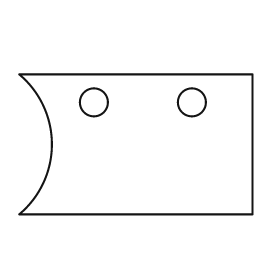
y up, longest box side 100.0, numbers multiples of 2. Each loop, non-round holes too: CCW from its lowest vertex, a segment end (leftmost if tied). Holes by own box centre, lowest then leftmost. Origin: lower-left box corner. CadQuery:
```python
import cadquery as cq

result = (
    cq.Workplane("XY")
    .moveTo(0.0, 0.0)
    .lineTo(100.0, 0.0)
    .lineTo(100.0, 60.0)
    .lineTo(0.0, 60.0)
    .threePointArc((14.0, 30.0), (0.0, 0.0))
    .close()
    .moveTo(32.0, 48.0)
    .circle(6.0)
    .moveTo(74.0, 48.0)
    .circle(6.0)
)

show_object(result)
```